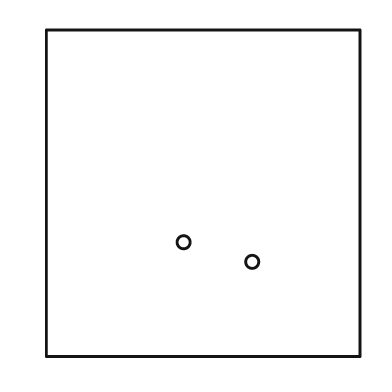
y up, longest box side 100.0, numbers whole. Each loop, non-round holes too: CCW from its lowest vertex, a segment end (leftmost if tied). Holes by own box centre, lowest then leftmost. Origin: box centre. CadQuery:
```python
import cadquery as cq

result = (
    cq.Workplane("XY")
    .moveTo(-48.0, -50.0)
    .lineTo(48.0, -50.0)
    .lineTo(48.0, 50.0)
    .lineTo(-48.0, 50.0)
    .close()
    .moveTo(15.0, -21.0)
    .circle(2.0)
    .moveTo(-6.0, -15.0)
    .circle(2.0)
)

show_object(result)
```